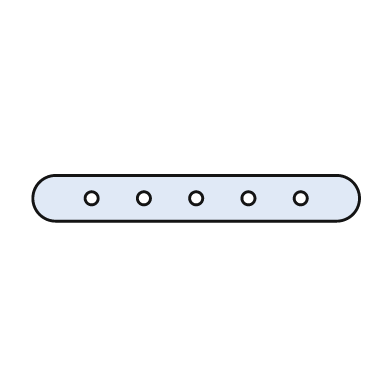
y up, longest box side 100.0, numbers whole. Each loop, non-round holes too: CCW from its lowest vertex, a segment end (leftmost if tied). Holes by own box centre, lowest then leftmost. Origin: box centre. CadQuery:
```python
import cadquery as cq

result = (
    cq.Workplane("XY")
    .moveTo(-43.0, -7.0)
    .lineTo(43.0, -7.0)
    .threePointArc((50.0, 0.0), (43.0, 7.0))
    .lineTo(-43.0, 7.0)
    .threePointArc((-50.0, 0.0), (-43.0, -7.0))
    .close()
    .moveTo(-32.0, 0.0)
    .circle(2.0)
    .moveTo(-16.0, 0.0)
    .circle(2.0)
    .moveTo(0.0, 0.0)
    .circle(2.0)
    .moveTo(16.0, 0.0)
    .circle(2.0)
    .moveTo(32.0, 0.0)
    .circle(2.0)
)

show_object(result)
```